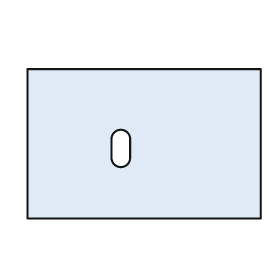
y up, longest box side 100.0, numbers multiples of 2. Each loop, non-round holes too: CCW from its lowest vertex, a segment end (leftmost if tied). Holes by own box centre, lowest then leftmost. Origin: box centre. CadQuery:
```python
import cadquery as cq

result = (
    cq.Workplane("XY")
    .moveTo(-50.0, -32.0)
    .lineTo(50.0, -32.0)
    .lineTo(50.0, 32.0)
    .lineTo(-50.0, 32.0)
    .close()
    .moveTo(-14.0, -6.0)
    .threePointArc((-10.0, -10.0), (-6.0, -6.0))
    .lineTo(-6.0, 2.0)
    .threePointArc((-10.0, 6.0), (-14.0, 2.0))
    .close()
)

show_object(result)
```